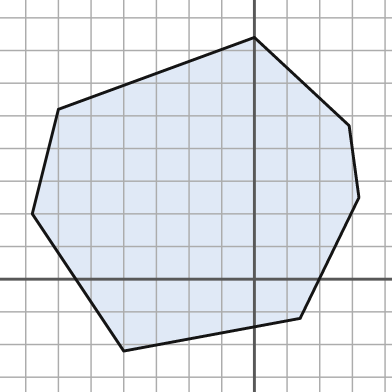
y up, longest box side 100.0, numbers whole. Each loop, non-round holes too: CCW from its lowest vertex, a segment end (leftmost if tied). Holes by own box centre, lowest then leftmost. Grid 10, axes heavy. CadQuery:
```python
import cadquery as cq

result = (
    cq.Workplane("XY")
    .moveTo(-40.0, -22.0)
    .lineTo(14.0, -12.0)
    .lineTo(32.0, 25.0)
    .lineTo(29.0, 47.0)
    .lineTo(0.0, 74.0)
    .lineTo(-60.0, 52.0)
    .lineTo(-68.0, 20.0)
    .close()
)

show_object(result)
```